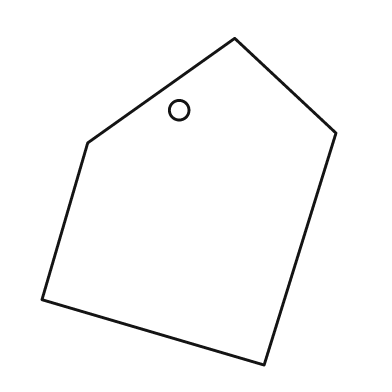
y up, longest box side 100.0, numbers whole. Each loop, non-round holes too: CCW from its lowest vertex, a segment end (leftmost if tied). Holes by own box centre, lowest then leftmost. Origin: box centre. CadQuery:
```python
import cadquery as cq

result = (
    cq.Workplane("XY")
    .moveTo(23.0, -50.0)
    .lineTo(45.0, 21.0)
    .lineTo(14.0, 50.0)
    .lineTo(-31.0, 18.0)
    .lineTo(-45.0, -30.0)
    .close()
    .moveTo(-3.0, 28.0)
    .circle(3.0)
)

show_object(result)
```